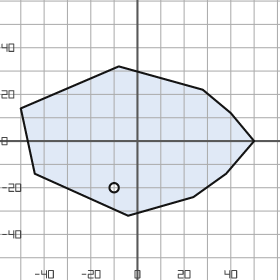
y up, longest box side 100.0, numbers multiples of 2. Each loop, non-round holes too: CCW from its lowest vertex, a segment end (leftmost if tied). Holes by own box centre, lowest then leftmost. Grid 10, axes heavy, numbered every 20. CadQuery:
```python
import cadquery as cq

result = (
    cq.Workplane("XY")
    .moveTo(-4.0, -32.0)
    .lineTo(24.0, -24.0)
    .lineTo(38.0, -14.0)
    .lineTo(50.0, 0.0)
    .lineTo(40.0, 12.0)
    .lineTo(28.0, 22.0)
    .lineTo(-8.0, 32.0)
    .lineTo(-50.0, 14.0)
    .lineTo(-44.0, -14.0)
    .close()
    .moveTo(-10.0, -20.0)
    .circle(2.0)
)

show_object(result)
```